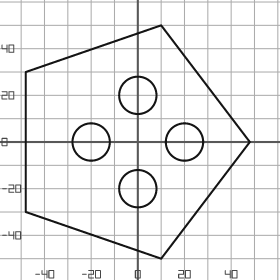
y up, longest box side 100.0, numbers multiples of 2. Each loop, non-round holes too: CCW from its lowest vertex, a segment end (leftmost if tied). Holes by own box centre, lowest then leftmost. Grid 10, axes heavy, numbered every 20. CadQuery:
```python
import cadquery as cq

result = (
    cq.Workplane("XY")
    .moveTo(10.0, -50.0)
    .lineTo(48.0, 0.0)
    .lineTo(10.0, 50.0)
    .lineTo(-48.0, 30.0)
    .lineTo(-48.0, -30.0)
    .close()
    .moveTo(0.0, -20.0)
    .circle(8.0)
    .moveTo(-20.0, 0.0)
    .circle(8.0)
    .moveTo(20.0, 0.0)
    .circle(8.0)
    .moveTo(0.0, 20.0)
    .circle(8.0)
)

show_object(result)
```